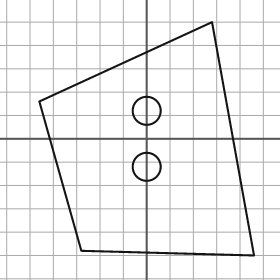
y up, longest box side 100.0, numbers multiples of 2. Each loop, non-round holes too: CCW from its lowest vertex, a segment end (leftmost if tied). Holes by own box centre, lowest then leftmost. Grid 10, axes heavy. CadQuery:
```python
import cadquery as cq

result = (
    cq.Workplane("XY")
    .moveTo(46.0, -50.0)
    .lineTo(28.0, 50.0)
    .lineTo(-46.0, 16.0)
    .lineTo(-28.0, -48.0)
    .close()
    .moveTo(0.0, -12.0)
    .circle(6.0)
    .moveTo(0.0, 12.0)
    .circle(6.0)
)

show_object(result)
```